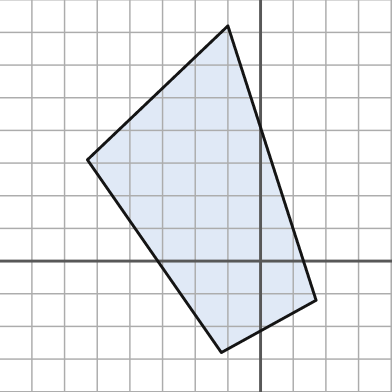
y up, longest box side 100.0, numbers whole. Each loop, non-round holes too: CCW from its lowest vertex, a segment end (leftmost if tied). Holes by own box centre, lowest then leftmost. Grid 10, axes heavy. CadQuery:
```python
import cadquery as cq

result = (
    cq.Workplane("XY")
    .moveTo(-12.0, -28.0)
    .lineTo(17.0, -12.0)
    .lineTo(-10.0, 72.0)
    .lineTo(-53.0, 31.0)
    .close()
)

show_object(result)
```